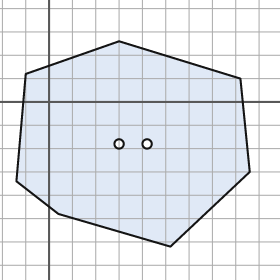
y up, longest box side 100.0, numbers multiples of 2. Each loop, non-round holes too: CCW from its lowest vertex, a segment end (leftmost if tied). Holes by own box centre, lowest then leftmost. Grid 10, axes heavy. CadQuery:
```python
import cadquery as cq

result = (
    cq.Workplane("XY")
    .moveTo(52.0, -62.0)
    .lineTo(86.0, -30.0)
    .lineTo(82.0, 10.0)
    .lineTo(30.0, 26.0)
    .lineTo(-10.0, 12.0)
    .lineTo(-14.0, -34.0)
    .lineTo(4.0, -48.0)
    .close()
    .moveTo(30.0, -18.0)
    .circle(2.0)
    .moveTo(42.0, -18.0)
    .circle(2.0)
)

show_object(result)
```